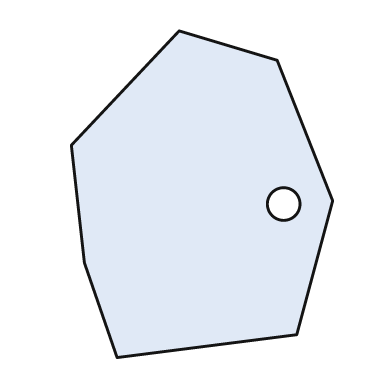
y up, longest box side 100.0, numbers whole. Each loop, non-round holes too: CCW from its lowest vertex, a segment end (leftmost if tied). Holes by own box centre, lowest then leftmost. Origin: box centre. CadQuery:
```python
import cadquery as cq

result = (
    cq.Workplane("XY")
    .moveTo(-26.0, -50.0)
    .lineTo(29.0, -43.0)
    .lineTo(40.0, -2.0)
    .lineTo(23.0, 41.0)
    .lineTo(-7.0, 50.0)
    .lineTo(-40.0, 15.0)
    .lineTo(-36.0, -21.0)
    .close()
    .moveTo(25.0, -3.0)
    .circle(5.0)
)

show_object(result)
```